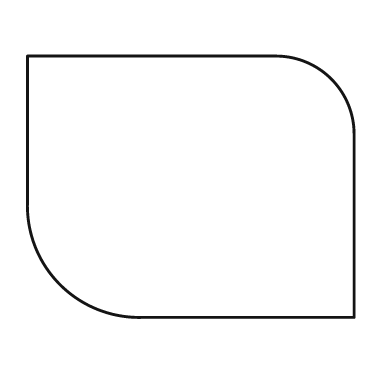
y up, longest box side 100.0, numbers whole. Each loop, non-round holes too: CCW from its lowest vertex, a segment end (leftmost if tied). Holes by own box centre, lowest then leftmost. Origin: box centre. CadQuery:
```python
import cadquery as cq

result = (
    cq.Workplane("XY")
    .moveTo(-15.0, -40.0)
    .lineTo(50.0, -40.0)
    .lineTo(50.0, 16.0)
    .threePointArc((43.0, 33.0), (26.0, 40.0))
    .lineTo(-50.0, 40.0)
    .lineTo(-50.0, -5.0)
    .threePointArc((-40.0, -30.0), (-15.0, -40.0))
    .close()
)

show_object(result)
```